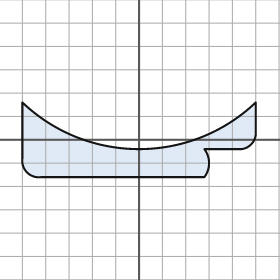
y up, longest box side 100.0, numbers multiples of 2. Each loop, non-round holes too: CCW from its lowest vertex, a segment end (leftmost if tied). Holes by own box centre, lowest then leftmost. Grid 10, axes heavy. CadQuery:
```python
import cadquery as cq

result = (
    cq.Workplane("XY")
    .moveTo(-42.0, -16.0)
    .lineTo(28.0, -16.0)
    .threePointArc((30.0, -10.0), (28.0, -4.0))
    .lineTo(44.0, -4.0)
    .threePointArc((48.0, -2.0), (50.0, 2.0))
    .lineTo(50.0, 16.0)
    .threePointArc((0.0, -4.0), (-50.0, 16.0))
    .lineTo(-50.0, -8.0)
    .threePointArc((-48.0, -14.0), (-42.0, -16.0))
    .close()
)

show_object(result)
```